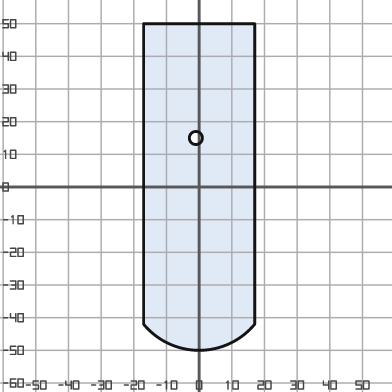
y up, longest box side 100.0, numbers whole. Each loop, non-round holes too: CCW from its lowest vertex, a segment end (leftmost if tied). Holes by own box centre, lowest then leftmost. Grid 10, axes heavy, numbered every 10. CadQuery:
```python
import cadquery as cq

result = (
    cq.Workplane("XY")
    .moveTo(-17.0, -42.0)
    .threePointArc((0.0, -50.0), (17.0, -42.0))
    .lineTo(17.0, 50.0)
    .lineTo(-17.0, 50.0)
    .close()
    .moveTo(-1.0, 15.0)
    .circle(2.0)
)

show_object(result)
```